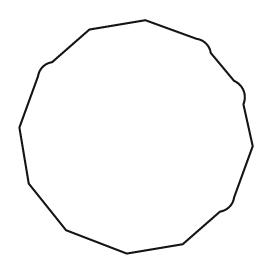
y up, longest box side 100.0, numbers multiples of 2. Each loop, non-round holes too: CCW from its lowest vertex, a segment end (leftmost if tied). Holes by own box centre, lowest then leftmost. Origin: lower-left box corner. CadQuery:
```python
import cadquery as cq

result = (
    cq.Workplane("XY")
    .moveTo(46.0, 0.0)
    .lineTo(70.0, 4.0)
    .lineTo(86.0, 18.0)
    .threePointArc((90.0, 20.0), (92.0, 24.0))
    .lineTo(100.0, 46.0)
    .lineTo(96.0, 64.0)
    .threePointArc((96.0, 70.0), (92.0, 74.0))
    .lineTo(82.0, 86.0)
    .threePointArc((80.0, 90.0), (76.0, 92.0))
    .lineTo(54.0, 100.0)
    .lineTo(30.0, 96.0)
    .lineTo(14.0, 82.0)
    .threePointArc((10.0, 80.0), (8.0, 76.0))
    .lineTo(0.0, 54.0)
    .lineTo(4.0, 30.0)
    .lineTo(20.0, 10.0)
    .close()
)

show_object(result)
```